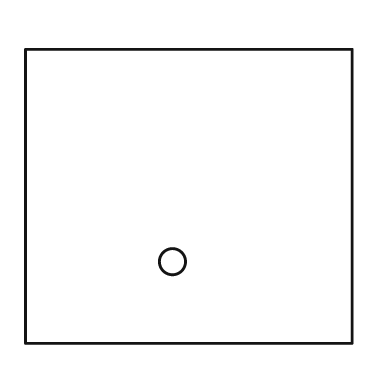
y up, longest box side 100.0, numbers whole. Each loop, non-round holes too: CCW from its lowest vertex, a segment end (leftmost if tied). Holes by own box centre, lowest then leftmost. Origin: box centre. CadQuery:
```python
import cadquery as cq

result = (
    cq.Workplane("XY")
    .moveTo(-50.0, -45.0)
    .lineTo(50.0, -45.0)
    .lineTo(50.0, 45.0)
    .lineTo(-50.0, 45.0)
    .close()
    .moveTo(-5.0, -20.0)
    .circle(4.0)
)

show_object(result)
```